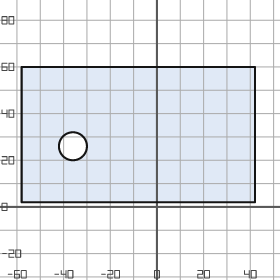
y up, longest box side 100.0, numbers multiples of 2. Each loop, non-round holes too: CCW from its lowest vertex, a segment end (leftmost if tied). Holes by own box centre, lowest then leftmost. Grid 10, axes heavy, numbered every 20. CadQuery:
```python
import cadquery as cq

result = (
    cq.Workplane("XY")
    .moveTo(-58.0, 2.0)
    .lineTo(42.0, 2.0)
    .lineTo(42.0, 60.0)
    .lineTo(-58.0, 60.0)
    .close()
    .moveTo(-36.0, 26.0)
    .circle(6.0)
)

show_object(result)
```